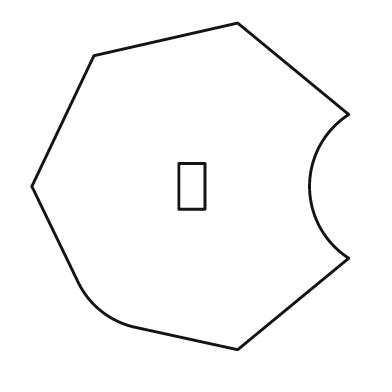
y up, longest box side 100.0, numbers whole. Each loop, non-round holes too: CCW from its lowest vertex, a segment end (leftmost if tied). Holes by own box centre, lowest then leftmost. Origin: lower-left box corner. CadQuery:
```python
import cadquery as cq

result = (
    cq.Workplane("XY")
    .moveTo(63.0, 0.0)
    .lineTo(97.0, 28.0)
    .threePointArc((85.0, 50.0), (97.0, 72.0))
    .lineTo(63.0, 100.0)
    .lineTo(19.0, 90.0)
    .lineTo(0.0, 50.0)
    .lineTo(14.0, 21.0)
    .threePointArc((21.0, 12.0), (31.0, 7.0))
    .close()
    .moveTo(45.0, 43.0)
    .lineTo(53.0, 43.0)
    .lineTo(53.0, 57.0)
    .lineTo(45.0, 57.0)
    .close()
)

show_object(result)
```